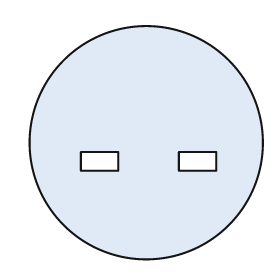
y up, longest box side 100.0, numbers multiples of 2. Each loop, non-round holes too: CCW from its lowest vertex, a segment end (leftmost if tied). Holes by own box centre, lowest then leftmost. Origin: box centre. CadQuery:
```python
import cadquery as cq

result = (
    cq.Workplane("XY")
    .moveTo(0.0, 0.0)
    .circle(50.0)
    .moveTo(-28.0, -12.0)
    .lineTo(-12.0, -12.0)
    .lineTo(-12.0, -4.0)
    .lineTo(-28.0, -4.0)
    .close()
    .moveTo(14.0, -12.0)
    .lineTo(30.0, -12.0)
    .lineTo(30.0, -4.0)
    .lineTo(14.0, -4.0)
    .close()
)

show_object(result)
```